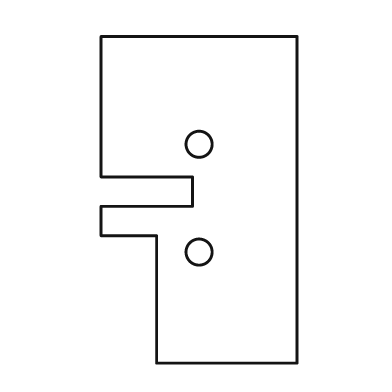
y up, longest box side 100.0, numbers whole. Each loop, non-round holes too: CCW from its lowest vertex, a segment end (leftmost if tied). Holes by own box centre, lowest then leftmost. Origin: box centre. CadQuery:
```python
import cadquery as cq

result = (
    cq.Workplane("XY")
    .moveTo(-13.0, -50.0)
    .lineTo(30.0, -50.0)
    .lineTo(30.0, 50.0)
    .lineTo(-30.0, 50.0)
    .lineTo(-30.0, 7.0)
    .lineTo(-2.0, 7.0)
    .lineTo(-2.0, -2.0)
    .lineTo(-30.0, -2.0)
    .lineTo(-30.0, -11.0)
    .lineTo(-13.0, -11.0)
    .close()
    .moveTo(0.0, -16.0)
    .circle(4.0)
    .moveTo(0.0, 17.0)
    .circle(4.0)
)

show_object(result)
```